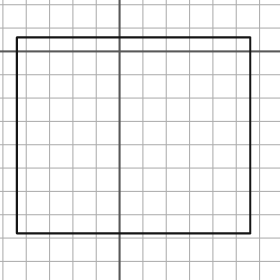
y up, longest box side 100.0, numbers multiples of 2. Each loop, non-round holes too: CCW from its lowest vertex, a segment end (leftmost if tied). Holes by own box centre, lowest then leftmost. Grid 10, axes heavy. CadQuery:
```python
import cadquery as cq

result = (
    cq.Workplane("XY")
    .moveTo(-44.0, -78.0)
    .lineTo(56.0, -78.0)
    .lineTo(56.0, 6.0)
    .lineTo(-44.0, 6.0)
    .close()
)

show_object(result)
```